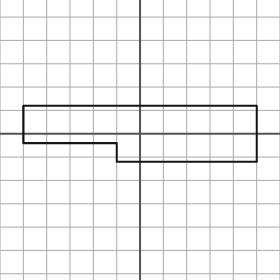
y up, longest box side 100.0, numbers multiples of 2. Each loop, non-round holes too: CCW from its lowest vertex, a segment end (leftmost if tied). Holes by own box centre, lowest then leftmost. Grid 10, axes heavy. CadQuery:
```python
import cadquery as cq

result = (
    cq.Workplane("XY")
    .moveTo(-10.0, -12.0)
    .lineTo(50.0, -12.0)
    .lineTo(50.0, 12.0)
    .lineTo(-50.0, 12.0)
    .lineTo(-50.0, -4.0)
    .lineTo(-10.0, -4.0)
    .close()
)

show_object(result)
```